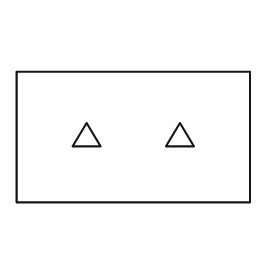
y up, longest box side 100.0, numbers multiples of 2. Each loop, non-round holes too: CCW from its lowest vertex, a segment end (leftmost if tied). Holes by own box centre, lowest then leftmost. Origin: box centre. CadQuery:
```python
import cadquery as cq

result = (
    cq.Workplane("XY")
    .moveTo(-50.0, -28.0)
    .lineTo(50.0, -28.0)
    .lineTo(50.0, 28.0)
    .lineTo(-50.0, 28.0)
    .close()
    .moveTo(-26.0, -4.0)
    .lineTo(-14.0, -4.0)
    .lineTo(-20.0, 6.0)
    .close()
    .moveTo(14.0, -4.0)
    .lineTo(26.0, -4.0)
    .lineTo(20.0, 6.0)
    .close()
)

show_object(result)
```